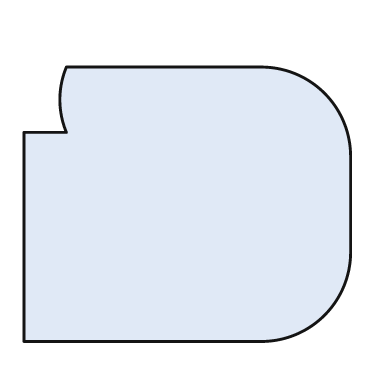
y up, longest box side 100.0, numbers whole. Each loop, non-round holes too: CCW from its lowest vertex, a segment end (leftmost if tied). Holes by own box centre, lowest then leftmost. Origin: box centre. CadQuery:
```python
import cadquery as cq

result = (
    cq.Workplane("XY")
    .moveTo(-50.0, -42.0)
    .lineTo(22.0, -42.0)
    .threePointArc((42.0, -34.0), (50.0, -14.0))
    .lineTo(50.0, 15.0)
    .threePointArc((42.0, 34.0), (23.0, 42.0))
    .lineTo(-37.0, 42.0)
    .threePointArc((-39.0, 32.0), (-37.0, 22.0))
    .lineTo(-50.0, 22.0)
    .close()
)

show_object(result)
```